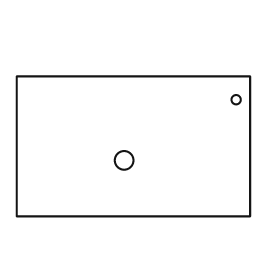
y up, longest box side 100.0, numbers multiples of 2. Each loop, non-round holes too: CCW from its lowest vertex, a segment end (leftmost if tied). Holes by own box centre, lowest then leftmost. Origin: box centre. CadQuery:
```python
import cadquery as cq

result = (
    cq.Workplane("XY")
    .moveTo(-50.0, -30.0)
    .lineTo(50.0, -30.0)
    .lineTo(50.0, 30.0)
    .lineTo(-50.0, 30.0)
    .close()
    .moveTo(-4.0, -6.0)
    .circle(4.0)
    .moveTo(44.0, 20.0)
    .circle(2.0)
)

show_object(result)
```